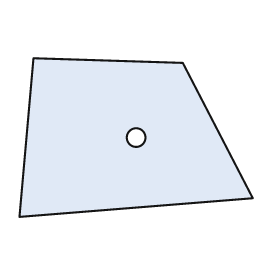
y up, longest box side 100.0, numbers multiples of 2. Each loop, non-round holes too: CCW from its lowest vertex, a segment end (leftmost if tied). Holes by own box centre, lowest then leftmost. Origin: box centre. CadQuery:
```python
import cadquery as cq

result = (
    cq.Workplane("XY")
    .moveTo(-50.0, -34.0)
    .lineTo(50.0, -26.0)
    .lineTo(20.0, 32.0)
    .lineTo(-44.0, 34.0)
    .close()
    .moveTo(0.0, 0.0)
    .circle(4.0)
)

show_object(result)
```